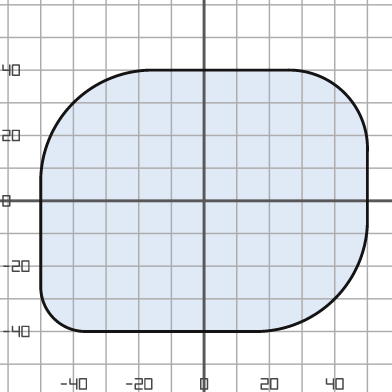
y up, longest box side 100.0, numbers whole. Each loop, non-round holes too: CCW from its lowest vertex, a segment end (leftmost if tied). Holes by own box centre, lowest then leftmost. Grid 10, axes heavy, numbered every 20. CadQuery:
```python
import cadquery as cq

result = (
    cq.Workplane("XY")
    .moveTo(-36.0, -40.0)
    .lineTo(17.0, -40.0)
    .threePointArc((40.0, -30.0), (50.0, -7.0))
    .lineTo(50.0, 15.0)
    .threePointArc((43.0, 33.0), (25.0, 40.0))
    .lineTo(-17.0, 40.0)
    .threePointArc((-40.0, 30.0), (-50.0, 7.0))
    .lineTo(-50.0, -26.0)
    .threePointArc((-46.0, -36.0), (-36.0, -40.0))
    .close()
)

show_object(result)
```